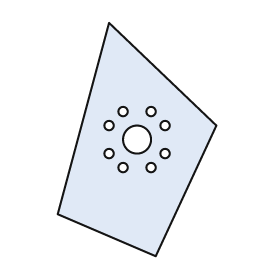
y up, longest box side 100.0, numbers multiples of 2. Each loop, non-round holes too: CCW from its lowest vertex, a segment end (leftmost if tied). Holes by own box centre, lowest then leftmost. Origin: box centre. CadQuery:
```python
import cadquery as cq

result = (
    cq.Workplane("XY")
    .moveTo(8.0, -50.0)
    .lineTo(34.0, 6.0)
    .lineTo(-12.0, 50.0)
    .lineTo(-34.0, -32.0)
    .close()
    .moveTo(-6.0, -12.0)
    .circle(2.0)
    .moveTo(6.0, -12.0)
    .circle(2.0)
    .moveTo(-12.0, -6.0)
    .circle(2.0)
    .moveTo(12.0, -6.0)
    .circle(2.0)
    .moveTo(0.0, 0.0)
    .circle(6.0)
    .moveTo(-12.0, 6.0)
    .circle(2.0)
    .moveTo(12.0, 6.0)
    .circle(2.0)
    .moveTo(-6.0, 12.0)
    .circle(2.0)
    .moveTo(6.0, 12.0)
    .circle(2.0)
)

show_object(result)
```